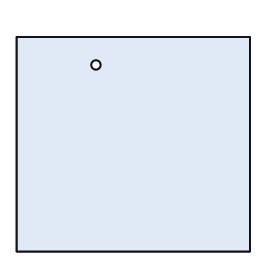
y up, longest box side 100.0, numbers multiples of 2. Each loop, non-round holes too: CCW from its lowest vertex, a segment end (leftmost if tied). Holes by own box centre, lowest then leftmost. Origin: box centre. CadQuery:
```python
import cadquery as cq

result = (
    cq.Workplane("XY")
    .moveTo(-50.0, -46.0)
    .lineTo(50.0, -46.0)
    .lineTo(50.0, 46.0)
    .lineTo(-50.0, 46.0)
    .close()
    .moveTo(-16.0, 34.0)
    .circle(2.0)
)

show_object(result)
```